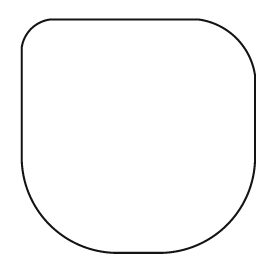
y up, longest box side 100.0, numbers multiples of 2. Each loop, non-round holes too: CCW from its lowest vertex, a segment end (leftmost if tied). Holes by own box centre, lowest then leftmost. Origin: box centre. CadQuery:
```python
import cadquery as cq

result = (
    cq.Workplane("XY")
    .moveTo(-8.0, -50.0)
    .lineTo(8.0, -50.0)
    .threePointArc((38.0, -38.0), (50.0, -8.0))
    .lineTo(50.0, 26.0)
    .threePointArc((42.0, 42.0), (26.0, 50.0))
    .lineTo(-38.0, 50.0)
    .threePointArc((-46.0, 46.0), (-50.0, 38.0))
    .lineTo(-50.0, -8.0)
    .threePointArc((-38.0, -38.0), (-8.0, -50.0))
    .close()
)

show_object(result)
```